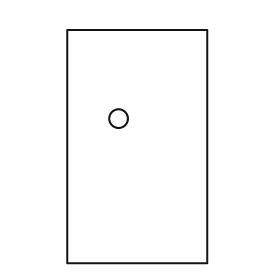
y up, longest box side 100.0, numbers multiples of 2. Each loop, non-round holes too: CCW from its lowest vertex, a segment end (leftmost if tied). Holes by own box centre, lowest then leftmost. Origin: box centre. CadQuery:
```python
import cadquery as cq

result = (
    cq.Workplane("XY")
    .moveTo(-30.0, -50.0)
    .lineTo(30.0, -50.0)
    .lineTo(30.0, 50.0)
    .lineTo(-30.0, 50.0)
    .close()
    .moveTo(-8.0, 12.0)
    .circle(4.0)
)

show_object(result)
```